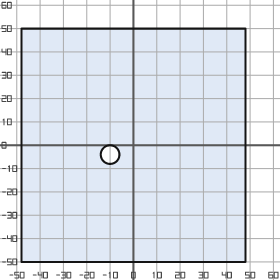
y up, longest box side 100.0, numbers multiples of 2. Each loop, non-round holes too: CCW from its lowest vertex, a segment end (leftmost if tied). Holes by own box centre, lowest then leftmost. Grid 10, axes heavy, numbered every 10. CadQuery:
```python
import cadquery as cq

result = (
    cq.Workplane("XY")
    .moveTo(-48.0, -50.0)
    .lineTo(48.0, -50.0)
    .lineTo(48.0, 50.0)
    .lineTo(-48.0, 50.0)
    .close()
    .moveTo(-10.0, -4.0)
    .circle(4.0)
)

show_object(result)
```